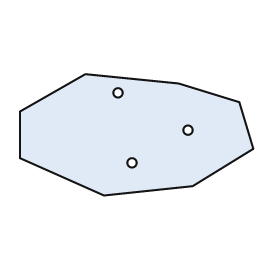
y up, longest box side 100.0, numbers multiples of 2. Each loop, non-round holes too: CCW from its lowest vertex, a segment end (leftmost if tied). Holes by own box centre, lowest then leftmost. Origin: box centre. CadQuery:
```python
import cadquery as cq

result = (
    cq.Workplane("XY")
    .moveTo(-14.0, -26.0)
    .lineTo(24.0, -22.0)
    .lineTo(50.0, -6.0)
    .lineTo(44.0, 14.0)
    .lineTo(18.0, 22.0)
    .lineTo(-22.0, 26.0)
    .lineTo(-50.0, 10.0)
    .lineTo(-50.0, -10.0)
    .close()
    .moveTo(-2.0, -12.0)
    .circle(2.0)
    .moveTo(22.0, 2.0)
    .circle(2.0)
    .moveTo(-8.0, 18.0)
    .circle(2.0)
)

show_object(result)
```